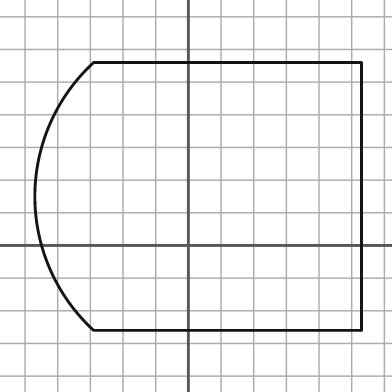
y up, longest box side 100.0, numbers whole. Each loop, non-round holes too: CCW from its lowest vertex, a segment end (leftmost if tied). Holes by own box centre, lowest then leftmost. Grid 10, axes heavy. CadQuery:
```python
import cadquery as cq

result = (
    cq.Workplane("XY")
    .moveTo(-29.0, -26.0)
    .lineTo(53.0, -26.0)
    .lineTo(53.0, 56.0)
    .lineTo(-29.0, 56.0)
    .threePointArc((-47.0, 15.0), (-29.0, -26.0))
    .close()
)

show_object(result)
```